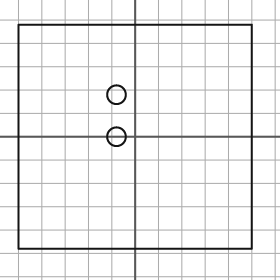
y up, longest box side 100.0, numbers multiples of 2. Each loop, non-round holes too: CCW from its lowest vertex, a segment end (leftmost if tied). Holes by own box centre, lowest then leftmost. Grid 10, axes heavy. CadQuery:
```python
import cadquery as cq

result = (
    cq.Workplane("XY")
    .moveTo(-50.0, -48.0)
    .lineTo(50.0, -48.0)
    .lineTo(50.0, 48.0)
    .lineTo(-50.0, 48.0)
    .close()
    .moveTo(-8.0, 0.0)
    .circle(4.0)
    .moveTo(-8.0, 18.0)
    .circle(4.0)
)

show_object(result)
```